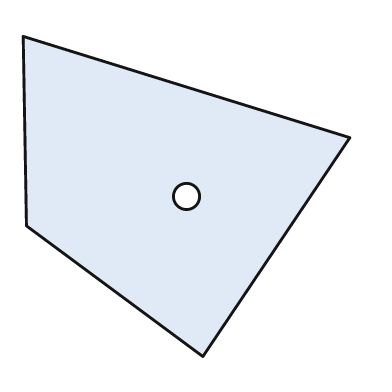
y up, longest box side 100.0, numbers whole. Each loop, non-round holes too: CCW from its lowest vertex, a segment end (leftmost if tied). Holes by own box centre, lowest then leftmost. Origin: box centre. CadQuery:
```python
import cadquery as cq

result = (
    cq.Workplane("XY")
    .moveTo(5.0, -49.0)
    .lineTo(50.0, 18.0)
    .lineTo(-50.0, 49.0)
    .lineTo(-49.0, -9.0)
    .close()
    .moveTo(0.0, 0.0)
    .circle(4.0)
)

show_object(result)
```